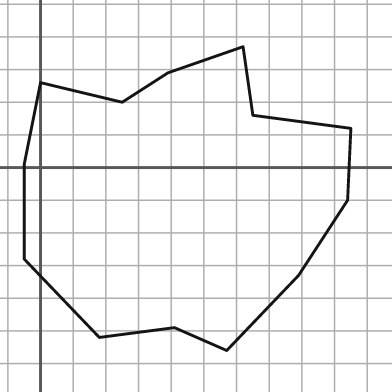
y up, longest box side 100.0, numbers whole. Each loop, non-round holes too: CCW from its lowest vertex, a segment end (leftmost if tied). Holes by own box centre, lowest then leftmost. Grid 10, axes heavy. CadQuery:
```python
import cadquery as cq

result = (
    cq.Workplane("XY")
    .moveTo(57.0, -56.0)
    .lineTo(79.0, -33.0)
    .lineTo(94.0, -10.0)
    .lineTo(95.0, 12.0)
    .lineTo(65.0, 16.0)
    .lineTo(62.0, 37.0)
    .lineTo(39.0, 29.0)
    .lineTo(25.0, 20.0)
    .lineTo(0.0, 26.0)
    .lineTo(-5.0, 1.0)
    .lineTo(-5.0, -28.0)
    .lineTo(18.0, -52.0)
    .lineTo(41.0, -49.0)
    .close()
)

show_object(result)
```